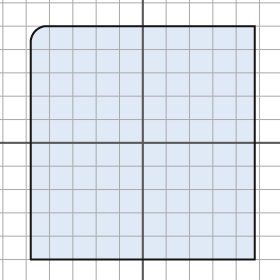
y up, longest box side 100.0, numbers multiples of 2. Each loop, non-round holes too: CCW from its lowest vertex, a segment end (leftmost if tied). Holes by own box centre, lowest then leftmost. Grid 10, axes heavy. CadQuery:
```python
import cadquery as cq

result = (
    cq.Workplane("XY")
    .moveTo(-48.0, -50.0)
    .lineTo(48.0, -50.0)
    .lineTo(48.0, 50.0)
    .lineTo(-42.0, 50.0)
    .threePointArc((-46.0, 48.0), (-48.0, 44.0))
    .close()
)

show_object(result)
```